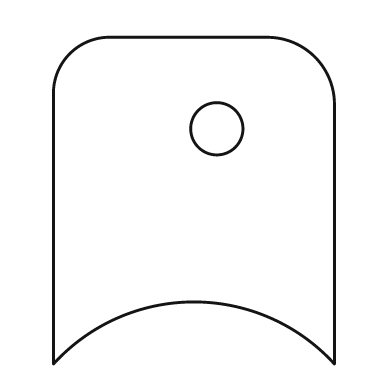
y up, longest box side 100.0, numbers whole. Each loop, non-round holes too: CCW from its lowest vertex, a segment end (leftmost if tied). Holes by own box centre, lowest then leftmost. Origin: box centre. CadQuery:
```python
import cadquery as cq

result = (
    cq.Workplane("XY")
    .moveTo(-43.0, -50.0)
    .threePointArc((0.0, -31.0), (43.0, -50.0))
    .lineTo(43.0, 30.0)
    .threePointArc((37.0, 44.0), (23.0, 50.0))
    .lineTo(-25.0, 50.0)
    .threePointArc((-38.0, 45.0), (-43.0, 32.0))
    .close()
    .moveTo(7.0, 22.0)
    .circle(8.0)
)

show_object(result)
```